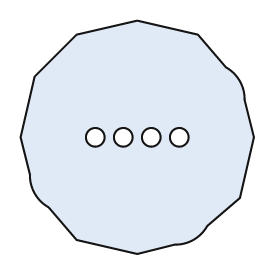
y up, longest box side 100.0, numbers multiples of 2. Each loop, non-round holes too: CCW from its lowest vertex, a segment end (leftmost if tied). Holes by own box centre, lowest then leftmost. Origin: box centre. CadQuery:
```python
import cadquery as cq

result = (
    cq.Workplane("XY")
    .moveTo(0.0, -50.0)
    .lineTo(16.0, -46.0)
    .threePointArc((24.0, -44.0), (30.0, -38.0))
    .lineTo(44.0, -26.0)
    .lineTo(50.0, 0.0)
    .lineTo(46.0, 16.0)
    .threePointArc((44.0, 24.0), (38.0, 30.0))
    .lineTo(26.0, 44.0)
    .lineTo(0.0, 50.0)
    .lineTo(-26.0, 44.0)
    .lineTo(-44.0, 26.0)
    .lineTo(-50.0, 0.0)
    .lineTo(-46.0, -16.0)
    .threePointArc((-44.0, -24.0), (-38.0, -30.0))
    .lineTo(-26.0, -44.0)
    .close()
    .moveTo(-18.0, 0.0)
    .circle(4.0)
    .moveTo(-6.0, 0.0)
    .circle(4.0)
    .moveTo(6.0, 0.0)
    .circle(4.0)
    .moveTo(18.0, 0.0)
    .circle(4.0)
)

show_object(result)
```